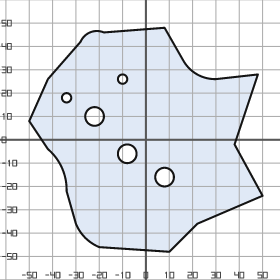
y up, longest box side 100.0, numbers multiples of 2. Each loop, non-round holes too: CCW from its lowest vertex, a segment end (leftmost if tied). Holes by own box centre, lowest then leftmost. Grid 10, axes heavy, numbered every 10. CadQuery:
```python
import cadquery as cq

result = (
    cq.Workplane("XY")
    .moveTo(10.0, -48.0)
    .lineTo(22.0, -36.0)
    .lineTo(50.0, -24.0)
    .lineTo(38.0, -2.0)
    .lineTo(48.0, 28.0)
    .lineTo(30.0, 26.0)
    .threePointArc((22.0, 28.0), (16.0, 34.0))
    .lineTo(8.0, 48.0)
    .lineTo(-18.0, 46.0)
    .threePointArc((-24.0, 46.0), (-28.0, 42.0))
    .lineTo(-42.0, 26.0)
    .lineTo(-50.0, 8.0)
    .lineTo(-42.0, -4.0)
    .threePointArc((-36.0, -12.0), (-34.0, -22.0))
    .lineTo(-30.0, -36.0)
    .threePointArc((-26.0, -42.0), (-20.0, -46.0))
    .close()
    .moveTo(8.0, -16.0)
    .circle(4.0)
    .moveTo(-8.0, -6.0)
    .circle(4.0)
    .moveTo(-22.0, 10.0)
    .circle(4.0)
    .moveTo(-34.0, 18.0)
    .circle(2.0)
    .moveTo(-10.0, 26.0)
    .circle(2.0)
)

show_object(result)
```